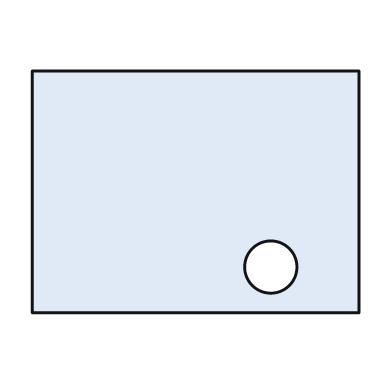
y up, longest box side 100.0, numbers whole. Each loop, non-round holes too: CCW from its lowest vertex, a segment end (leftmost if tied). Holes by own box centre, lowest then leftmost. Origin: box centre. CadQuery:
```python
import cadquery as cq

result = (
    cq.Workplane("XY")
    .moveTo(-50.0, -37.0)
    .lineTo(50.0, -37.0)
    .lineTo(50.0, 37.0)
    .lineTo(-50.0, 37.0)
    .close()
    .moveTo(23.0, -23.0)
    .circle(8.0)
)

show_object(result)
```